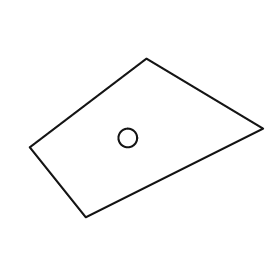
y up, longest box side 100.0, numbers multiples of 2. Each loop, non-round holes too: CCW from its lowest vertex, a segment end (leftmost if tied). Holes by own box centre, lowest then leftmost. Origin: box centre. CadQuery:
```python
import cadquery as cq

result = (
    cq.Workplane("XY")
    .moveTo(-26.0, -34.0)
    .lineTo(50.0, 4.0)
    .lineTo(0.0, 34.0)
    .lineTo(-50.0, -4.0)
    .close()
    .moveTo(-8.0, 0.0)
    .circle(4.0)
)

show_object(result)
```